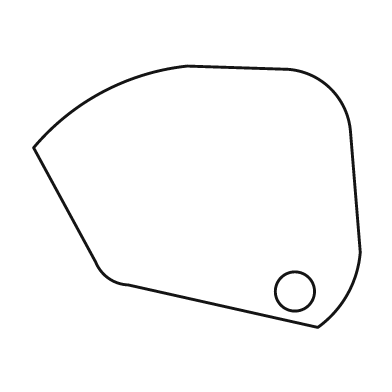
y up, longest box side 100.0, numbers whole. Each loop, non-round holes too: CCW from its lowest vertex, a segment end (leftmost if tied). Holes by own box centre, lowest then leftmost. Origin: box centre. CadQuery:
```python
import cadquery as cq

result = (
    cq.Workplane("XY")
    .moveTo(37.0, -40.0)
    .threePointArc((46.0, -30.0), (50.0, -17.0))
    .lineTo(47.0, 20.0)
    .threePointArc((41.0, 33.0), (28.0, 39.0))
    .lineTo(-3.0, 40.0)
    .threePointArc((-29.0, 32.0), (-50.0, 15.0))
    .lineTo(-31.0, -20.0)
    .threePointArc((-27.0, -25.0), (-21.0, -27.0))
    .close()
    .moveTo(30.0, -29.0)
    .circle(6.0)
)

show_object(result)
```